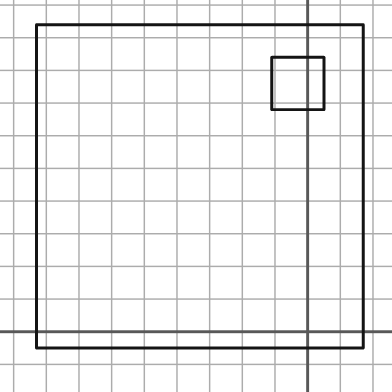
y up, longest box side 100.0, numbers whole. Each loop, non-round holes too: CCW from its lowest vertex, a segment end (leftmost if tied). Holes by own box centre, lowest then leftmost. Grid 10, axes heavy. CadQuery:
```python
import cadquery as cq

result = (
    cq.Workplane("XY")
    .moveTo(-83.0, -5.0)
    .lineTo(17.0, -5.0)
    .lineTo(17.0, 94.0)
    .lineTo(-83.0, 94.0)
    .close()
    .moveTo(-11.0, 68.0)
    .lineTo(5.0, 68.0)
    .lineTo(5.0, 84.0)
    .lineTo(-11.0, 84.0)
    .close()
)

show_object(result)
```